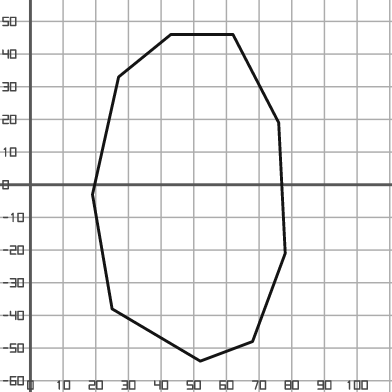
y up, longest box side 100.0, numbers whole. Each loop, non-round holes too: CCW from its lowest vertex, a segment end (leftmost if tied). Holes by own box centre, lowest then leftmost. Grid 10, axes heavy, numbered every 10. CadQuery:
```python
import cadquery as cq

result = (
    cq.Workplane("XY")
    .moveTo(52.0, -54.0)
    .lineTo(68.0, -48.0)
    .lineTo(78.0, -21.0)
    .lineTo(76.0, 19.0)
    .lineTo(62.0, 46.0)
    .lineTo(43.0, 46.0)
    .lineTo(27.0, 33.0)
    .lineTo(19.0, -3.0)
    .lineTo(25.0, -38.0)
    .close()
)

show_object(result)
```